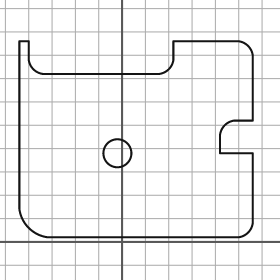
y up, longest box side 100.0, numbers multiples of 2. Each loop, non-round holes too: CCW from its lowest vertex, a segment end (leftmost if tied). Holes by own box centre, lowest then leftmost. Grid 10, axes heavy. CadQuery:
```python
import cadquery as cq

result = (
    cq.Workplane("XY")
    .moveTo(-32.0, 2.0)
    .lineTo(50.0, 2.0)
    .threePointArc((54.0, 4.0), (56.0, 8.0))
    .lineTo(56.0, 38.0)
    .lineTo(42.0, 38.0)
    .lineTo(42.0, 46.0)
    .threePointArc((44.0, 50.0), (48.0, 52.0))
    .lineTo(56.0, 52.0)
    .lineTo(56.0, 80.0)
    .threePointArc((54.0, 84.0), (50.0, 86.0))
    .lineTo(22.0, 86.0)
    .lineTo(22.0, 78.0)
    .threePointArc((20.0, 74.0), (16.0, 72.0))
    .lineTo(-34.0, 72.0)
    .threePointArc((-38.0, 74.0), (-40.0, 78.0))
    .lineTo(-40.0, 86.0)
    .lineTo(-44.0, 86.0)
    .lineTo(-44.0, 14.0)
    .threePointArc((-40.0, 6.0), (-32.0, 2.0))
    .close()
    .moveTo(-2.0, 38.0)
    .circle(6.0)
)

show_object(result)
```